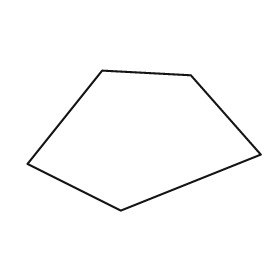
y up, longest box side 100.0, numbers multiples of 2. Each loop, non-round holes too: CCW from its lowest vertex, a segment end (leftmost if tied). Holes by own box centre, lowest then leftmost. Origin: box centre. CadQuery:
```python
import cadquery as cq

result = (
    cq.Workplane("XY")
    .moveTo(-10.0, -30.0)
    .lineTo(50.0, -6.0)
    .lineTo(20.0, 28.0)
    .lineTo(-18.0, 30.0)
    .lineTo(-50.0, -10.0)
    .close()
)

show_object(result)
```